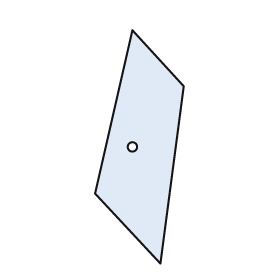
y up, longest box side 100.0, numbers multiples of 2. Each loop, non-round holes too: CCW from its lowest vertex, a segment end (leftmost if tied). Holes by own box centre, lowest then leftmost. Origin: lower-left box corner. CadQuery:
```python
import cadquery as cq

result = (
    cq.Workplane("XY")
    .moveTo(28.0, 0.0)
    .lineTo(38.0, 76.0)
    .lineTo(16.0, 100.0)
    .lineTo(0.0, 30.0)
    .close()
    .moveTo(16.0, 50.0)
    .circle(2.0)
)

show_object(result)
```